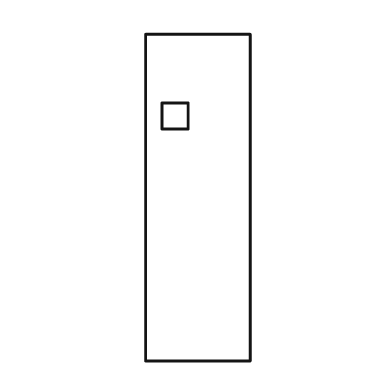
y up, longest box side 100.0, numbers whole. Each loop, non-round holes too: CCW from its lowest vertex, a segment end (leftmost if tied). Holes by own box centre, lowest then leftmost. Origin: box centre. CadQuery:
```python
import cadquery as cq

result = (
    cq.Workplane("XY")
    .moveTo(-16.0, -50.0)
    .lineTo(16.0, -50.0)
    .lineTo(16.0, 50.0)
    .lineTo(-16.0, 50.0)
    .close()
    .moveTo(-11.0, 21.0)
    .lineTo(-3.0, 21.0)
    .lineTo(-3.0, 29.0)
    .lineTo(-11.0, 29.0)
    .close()
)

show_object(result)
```